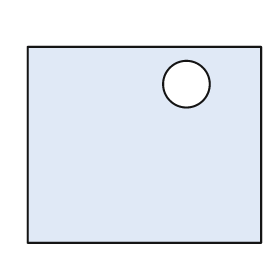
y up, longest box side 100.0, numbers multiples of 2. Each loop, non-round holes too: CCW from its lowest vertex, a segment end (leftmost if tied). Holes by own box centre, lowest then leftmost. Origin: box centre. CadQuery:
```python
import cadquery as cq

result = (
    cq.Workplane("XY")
    .moveTo(-50.0, -42.0)
    .lineTo(50.0, -42.0)
    .lineTo(50.0, 42.0)
    .lineTo(-50.0, 42.0)
    .close()
    .moveTo(18.0, 26.0)
    .circle(10.0)
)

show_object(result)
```